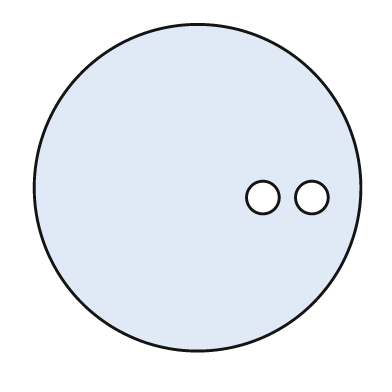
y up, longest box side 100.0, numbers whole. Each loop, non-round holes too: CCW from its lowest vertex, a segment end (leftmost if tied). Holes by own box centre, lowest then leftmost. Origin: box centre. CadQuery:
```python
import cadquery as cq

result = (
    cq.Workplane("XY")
    .moveTo(0.0, 0.0)
    .circle(50.0)
    .moveTo(20.0, -3.0)
    .circle(5.0)
    .moveTo(35.0, -3.0)
    .circle(5.0)
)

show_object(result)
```